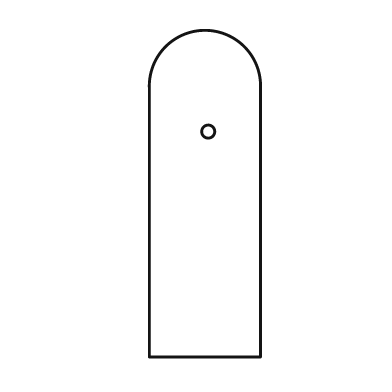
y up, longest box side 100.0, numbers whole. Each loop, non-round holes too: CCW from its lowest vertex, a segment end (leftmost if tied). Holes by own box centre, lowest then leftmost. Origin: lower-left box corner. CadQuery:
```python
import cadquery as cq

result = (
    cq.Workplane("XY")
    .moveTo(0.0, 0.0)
    .lineTo(34.0, 0.0)
    .lineTo(34.0, 82.0)
    .threePointArc((17.0, 100.0), (0.0, 82.0))
    .close()
    .moveTo(18.0, 69.0)
    .circle(2.0)
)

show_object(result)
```